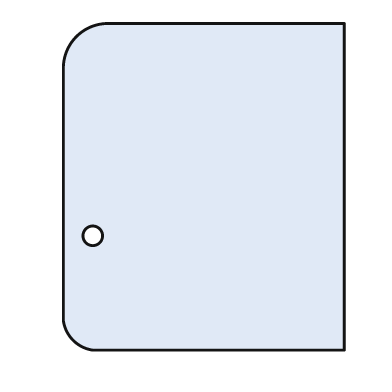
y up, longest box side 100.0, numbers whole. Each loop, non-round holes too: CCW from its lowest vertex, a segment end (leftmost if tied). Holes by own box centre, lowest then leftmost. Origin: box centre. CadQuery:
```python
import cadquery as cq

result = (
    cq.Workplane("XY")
    .moveTo(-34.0, -50.0)
    .lineTo(43.0, -50.0)
    .lineTo(43.0, 50.0)
    .lineTo(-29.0, 50.0)
    .threePointArc((-39.0, 46.0), (-43.0, 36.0))
    .lineTo(-43.0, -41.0)
    .threePointArc((-40.0, -47.0), (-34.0, -50.0))
    .close()
    .moveTo(-34.0, -15.0)
    .circle(3.0)
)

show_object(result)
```